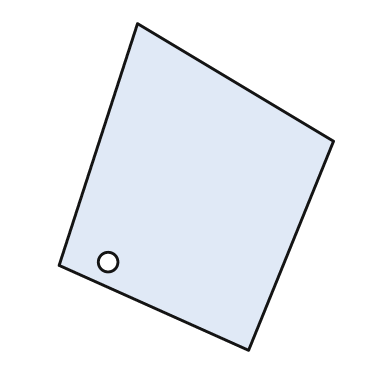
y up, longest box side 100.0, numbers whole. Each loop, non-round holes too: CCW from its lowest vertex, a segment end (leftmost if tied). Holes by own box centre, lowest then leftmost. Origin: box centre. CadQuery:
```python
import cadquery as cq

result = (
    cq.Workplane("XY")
    .moveTo(16.0, -50.0)
    .lineTo(42.0, 14.0)
    .lineTo(-18.0, 50.0)
    .lineTo(-42.0, -24.0)
    .close()
    .moveTo(-27.0, -23.0)
    .circle(3.0)
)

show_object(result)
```